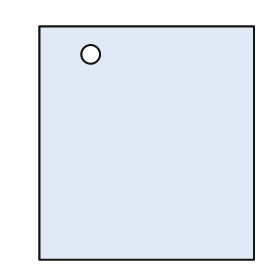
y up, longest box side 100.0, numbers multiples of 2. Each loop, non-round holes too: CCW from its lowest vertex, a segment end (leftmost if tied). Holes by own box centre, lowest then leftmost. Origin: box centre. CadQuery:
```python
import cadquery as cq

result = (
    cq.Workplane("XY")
    .moveTo(-46.0, -50.0)
    .lineTo(46.0, -50.0)
    .lineTo(46.0, 50.0)
    .lineTo(-46.0, 50.0)
    .close()
    .moveTo(-24.0, 38.0)
    .circle(4.0)
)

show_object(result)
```